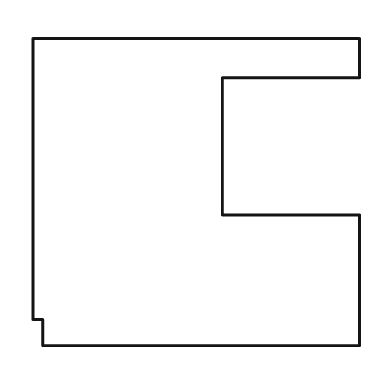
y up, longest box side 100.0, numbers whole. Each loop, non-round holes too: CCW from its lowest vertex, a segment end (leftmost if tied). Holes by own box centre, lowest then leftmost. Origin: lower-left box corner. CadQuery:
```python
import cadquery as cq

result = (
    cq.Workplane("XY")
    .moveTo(3.0, 0.0)
    .lineTo(100.0, 0.0)
    .lineTo(100.0, 40.0)
    .lineTo(58.0, 40.0)
    .lineTo(58.0, 82.0)
    .lineTo(100.0, 82.0)
    .lineTo(100.0, 94.0)
    .lineTo(0.0, 94.0)
    .lineTo(0.0, 8.0)
    .lineTo(3.0, 8.0)
    .close()
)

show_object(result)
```